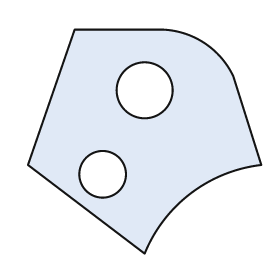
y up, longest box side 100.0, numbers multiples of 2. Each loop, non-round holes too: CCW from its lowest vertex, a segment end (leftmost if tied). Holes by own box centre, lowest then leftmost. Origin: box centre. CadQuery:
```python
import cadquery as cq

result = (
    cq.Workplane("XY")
    .moveTo(0.0, -48.0)
    .threePointArc((20.0, -22.0), (50.0, -10.0))
    .lineTo(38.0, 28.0)
    .threePointArc((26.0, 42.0), (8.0, 48.0))
    .lineTo(-30.0, 48.0)
    .lineTo(-50.0, -10.0)
    .close()
    .moveTo(-18.0, -14.0)
    .circle(10.0)
    .moveTo(0.0, 22.0)
    .circle(12.0)
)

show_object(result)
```